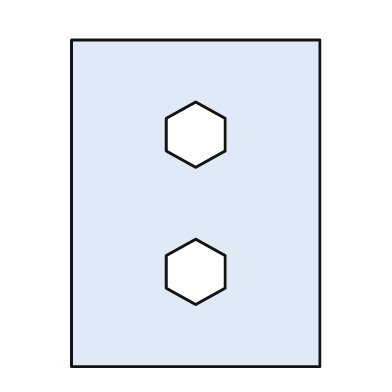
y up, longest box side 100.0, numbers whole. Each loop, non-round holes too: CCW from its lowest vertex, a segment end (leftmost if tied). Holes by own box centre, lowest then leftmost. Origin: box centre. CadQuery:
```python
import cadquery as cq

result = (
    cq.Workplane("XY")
    .moveTo(-38.0, -50.0)
    .lineTo(38.0, -50.0)
    .lineTo(38.0, 50.0)
    .lineTo(-38.0, 50.0)
    .close()
    .moveTo(0.0, -31.0)
    .lineTo(9.0, -26.0)
    .lineTo(9.0, -16.0)
    .lineTo(0.0, -11.0)
    .lineTo(-9.0, -16.0)
    .lineTo(-9.0, -26.0)
    .close()
    .moveTo(0.0, 11.0)
    .lineTo(9.0, 16.0)
    .lineTo(9.0, 26.0)
    .lineTo(0.0, 31.0)
    .lineTo(-9.0, 26.0)
    .lineTo(-9.0, 16.0)
    .close()
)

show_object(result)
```